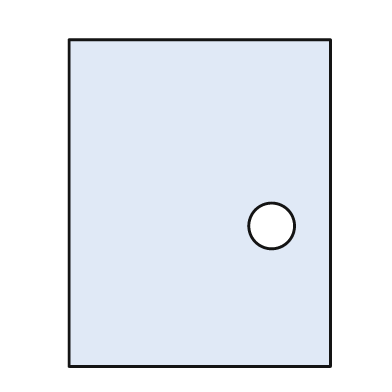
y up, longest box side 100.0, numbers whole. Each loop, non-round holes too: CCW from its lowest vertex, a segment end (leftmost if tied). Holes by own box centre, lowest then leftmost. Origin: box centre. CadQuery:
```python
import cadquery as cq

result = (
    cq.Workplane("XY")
    .moveTo(-40.0, -50.0)
    .lineTo(40.0, -50.0)
    .lineTo(40.0, 50.0)
    .lineTo(-40.0, 50.0)
    .close()
    .moveTo(22.0, -7.0)
    .circle(7.0)
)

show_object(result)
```